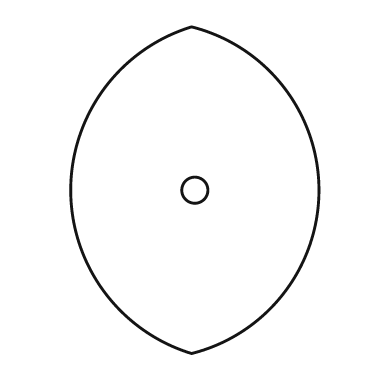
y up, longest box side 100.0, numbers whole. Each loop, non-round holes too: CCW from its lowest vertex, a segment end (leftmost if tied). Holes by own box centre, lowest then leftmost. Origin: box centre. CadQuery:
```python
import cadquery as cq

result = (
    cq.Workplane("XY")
    .moveTo(-1.0, -50.0)
    .threePointArc((38.0, 0.0), (-1.0, 50.0))
    .threePointArc((-38.0, 0.0), (-1.0, -50.0))
    .close()
    .moveTo(0.0, 0.0)
    .circle(4.0)
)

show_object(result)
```